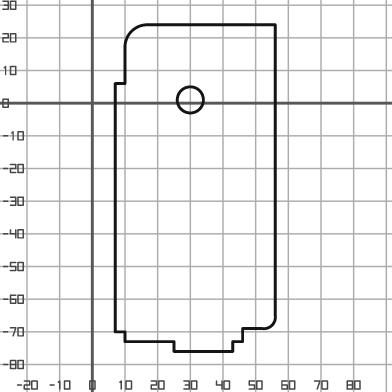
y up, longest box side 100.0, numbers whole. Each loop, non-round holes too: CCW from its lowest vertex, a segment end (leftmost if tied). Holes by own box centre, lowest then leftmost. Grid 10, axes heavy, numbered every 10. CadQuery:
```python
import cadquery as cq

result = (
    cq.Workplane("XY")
    .moveTo(25.0, -76.0)
    .lineTo(43.0, -76.0)
    .lineTo(43.0, -73.0)
    .lineTo(46.0, -73.0)
    .lineTo(46.0, -69.0)
    .lineTo(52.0, -69.0)
    .threePointArc((55.0, -68.0), (56.0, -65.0))
    .lineTo(56.0, 24.0)
    .lineTo(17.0, 24.0)
    .threePointArc((12.0, 22.0), (10.0, 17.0))
    .lineTo(10.0, 6.0)
    .lineTo(7.0, 6.0)
    .lineTo(7.0, -70.0)
    .lineTo(10.0, -70.0)
    .lineTo(10.0, -73.0)
    .lineTo(25.0, -73.0)
    .close()
    .moveTo(30.0, 1.0)
    .circle(4.0)
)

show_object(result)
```